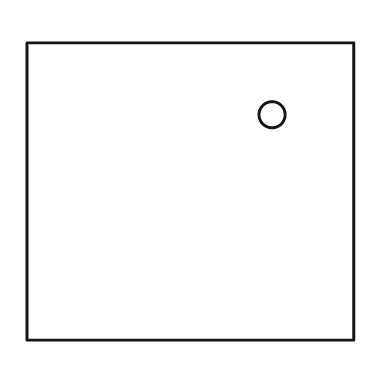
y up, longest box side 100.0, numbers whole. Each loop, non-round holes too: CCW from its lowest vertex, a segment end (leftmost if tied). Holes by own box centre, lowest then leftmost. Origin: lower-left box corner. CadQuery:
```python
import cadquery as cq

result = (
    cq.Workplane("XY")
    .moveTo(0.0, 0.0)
    .lineTo(100.0, 0.0)
    .lineTo(100.0, 91.0)
    .lineTo(0.0, 91.0)
    .close()
    .moveTo(75.0, 69.0)
    .circle(4.0)
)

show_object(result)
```